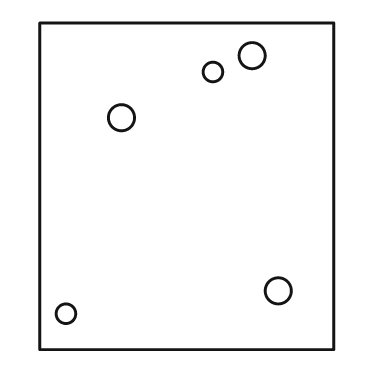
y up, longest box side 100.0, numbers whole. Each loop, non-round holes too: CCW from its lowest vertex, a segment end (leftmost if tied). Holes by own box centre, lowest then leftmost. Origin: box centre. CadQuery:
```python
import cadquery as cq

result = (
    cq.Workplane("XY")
    .moveTo(-45.0, -50.0)
    .lineTo(45.0, -50.0)
    .lineTo(45.0, 50.0)
    .lineTo(-45.0, 50.0)
    .close()
    .moveTo(-37.0, -39.0)
    .circle(3.0)
    .moveTo(28.0, -32.0)
    .circle(4.0)
    .moveTo(-20.0, 21.0)
    .circle(4.0)
    .moveTo(8.0, 35.0)
    .circle(3.0)
    .moveTo(20.0, 40.0)
    .circle(4.0)
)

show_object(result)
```